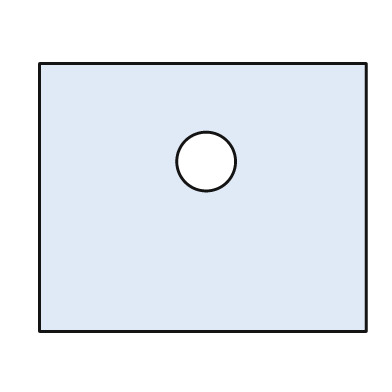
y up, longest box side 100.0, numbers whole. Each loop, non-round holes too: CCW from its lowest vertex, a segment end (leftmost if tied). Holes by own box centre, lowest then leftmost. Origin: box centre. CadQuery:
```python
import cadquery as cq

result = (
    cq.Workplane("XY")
    .moveTo(-50.0, -41.0)
    .lineTo(50.0, -41.0)
    .lineTo(50.0, 41.0)
    .lineTo(-50.0, 41.0)
    .close()
    .moveTo(1.0, 11.0)
    .circle(9.0)
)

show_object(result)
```